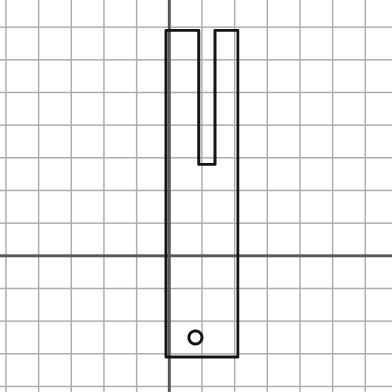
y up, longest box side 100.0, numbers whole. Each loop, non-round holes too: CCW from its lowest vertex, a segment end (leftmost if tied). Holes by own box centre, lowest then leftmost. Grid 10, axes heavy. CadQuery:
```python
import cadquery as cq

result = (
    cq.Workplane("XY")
    .moveTo(-1.0, -31.0)
    .lineTo(21.0, -31.0)
    .lineTo(21.0, 69.0)
    .lineTo(14.0, 69.0)
    .lineTo(14.0, 28.0)
    .lineTo(9.0, 28.0)
    .lineTo(9.0, 69.0)
    .lineTo(-1.0, 69.0)
    .close()
    .moveTo(8.0, -25.0)
    .circle(2.0)
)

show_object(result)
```